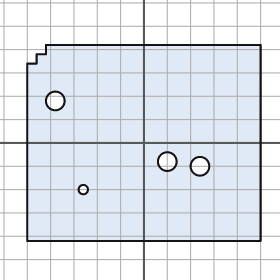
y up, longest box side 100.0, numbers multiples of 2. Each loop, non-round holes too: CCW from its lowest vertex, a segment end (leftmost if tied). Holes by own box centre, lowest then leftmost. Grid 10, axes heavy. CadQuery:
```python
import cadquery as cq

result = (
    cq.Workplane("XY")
    .moveTo(-50.0, -42.0)
    .lineTo(50.0, -42.0)
    .lineTo(50.0, 42.0)
    .lineTo(-42.0, 42.0)
    .lineTo(-42.0, 38.0)
    .lineTo(-46.0, 38.0)
    .lineTo(-46.0, 34.0)
    .lineTo(-50.0, 34.0)
    .close()
    .moveTo(-26.0, -20.0)
    .circle(2.0)
    .moveTo(24.0, -10.0)
    .circle(4.0)
    .moveTo(10.0, -8.0)
    .circle(4.0)
    .moveTo(-38.0, 18.0)
    .circle(4.0)
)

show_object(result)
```